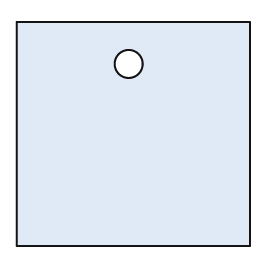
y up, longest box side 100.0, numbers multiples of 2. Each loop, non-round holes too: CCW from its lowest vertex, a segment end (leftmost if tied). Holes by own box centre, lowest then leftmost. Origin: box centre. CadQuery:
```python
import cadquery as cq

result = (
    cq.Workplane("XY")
    .moveTo(-50.0, -48.0)
    .lineTo(50.0, -48.0)
    .lineTo(50.0, 48.0)
    .lineTo(-50.0, 48.0)
    .close()
    .moveTo(-2.0, 30.0)
    .circle(6.0)
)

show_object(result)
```